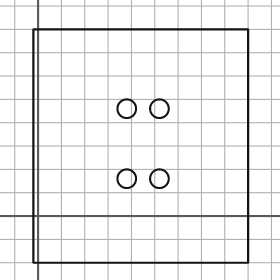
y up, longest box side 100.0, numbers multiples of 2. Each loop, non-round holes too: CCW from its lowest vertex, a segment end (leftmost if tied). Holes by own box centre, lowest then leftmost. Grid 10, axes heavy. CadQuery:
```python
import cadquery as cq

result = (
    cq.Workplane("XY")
    .moveTo(-2.0, -20.0)
    .lineTo(90.0, -20.0)
    .lineTo(90.0, 80.0)
    .lineTo(-2.0, 80.0)
    .close()
    .moveTo(38.0, 16.0)
    .circle(4.0)
    .moveTo(52.0, 16.0)
    .circle(4.0)
    .moveTo(38.0, 46.0)
    .circle(4.0)
    .moveTo(52.0, 46.0)
    .circle(4.0)
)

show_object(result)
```